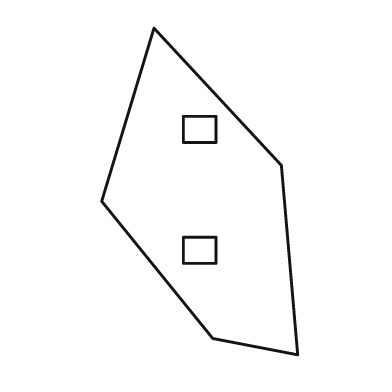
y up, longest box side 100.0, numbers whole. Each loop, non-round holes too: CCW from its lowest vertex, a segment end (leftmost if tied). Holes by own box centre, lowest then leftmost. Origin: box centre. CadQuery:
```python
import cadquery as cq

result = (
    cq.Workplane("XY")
    .moveTo(30.0, -50.0)
    .lineTo(25.0, 8.0)
    .lineTo(-14.0, 50.0)
    .lineTo(-30.0, -3.0)
    .lineTo(4.0, -45.0)
    .close()
    .moveTo(-5.0, -22.0)
    .lineTo(5.0, -22.0)
    .lineTo(5.0, -14.0)
    .lineTo(-5.0, -14.0)
    .close()
    .moveTo(-5.0, 15.0)
    .lineTo(5.0, 15.0)
    .lineTo(5.0, 23.0)
    .lineTo(-5.0, 23.0)
    .close()
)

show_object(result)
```